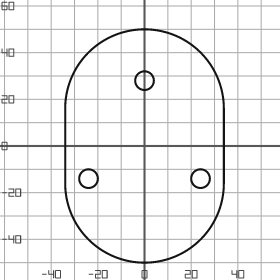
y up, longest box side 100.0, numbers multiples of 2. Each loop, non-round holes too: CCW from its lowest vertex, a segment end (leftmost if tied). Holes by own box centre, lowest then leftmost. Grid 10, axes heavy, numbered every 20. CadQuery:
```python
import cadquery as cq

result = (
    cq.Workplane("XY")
    .moveTo(-34.0, -16.0)
    .threePointArc((0.0, -50.0), (34.0, -16.0))
    .lineTo(34.0, 16.0)
    .threePointArc((0.0, 50.0), (-34.0, 16.0))
    .close()
    .moveTo(-24.0, -14.0)
    .circle(4.0)
    .moveTo(24.0, -14.0)
    .circle(4.0)
    .moveTo(0.0, 28.0)
    .circle(4.0)
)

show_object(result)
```